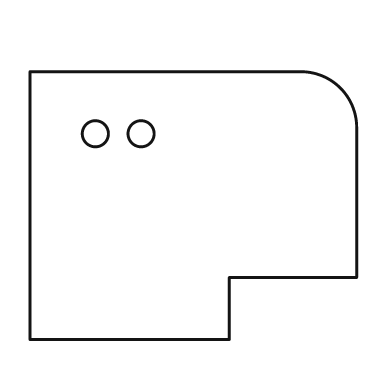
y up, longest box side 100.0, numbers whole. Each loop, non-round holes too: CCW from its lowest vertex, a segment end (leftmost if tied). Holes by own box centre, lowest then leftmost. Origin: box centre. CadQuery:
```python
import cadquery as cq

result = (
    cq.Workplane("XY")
    .moveTo(-50.0, -41.0)
    .lineTo(11.0, -41.0)
    .lineTo(11.0, -22.0)
    .lineTo(50.0, -22.0)
    .lineTo(50.0, 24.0)
    .threePointArc((45.0, 36.0), (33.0, 41.0))
    .lineTo(-50.0, 41.0)
    .close()
    .moveTo(-30.0, 22.0)
    .circle(4.0)
    .moveTo(-16.0, 22.0)
    .circle(4.0)
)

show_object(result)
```